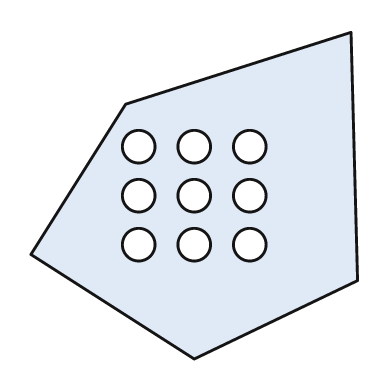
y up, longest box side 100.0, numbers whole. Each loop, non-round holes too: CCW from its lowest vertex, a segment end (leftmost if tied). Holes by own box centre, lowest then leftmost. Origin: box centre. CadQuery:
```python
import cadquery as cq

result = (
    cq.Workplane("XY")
    .moveTo(0.0, -50.0)
    .lineTo(50.0, -26.0)
    .lineTo(48.0, 50.0)
    .lineTo(-21.0, 28.0)
    .lineTo(-50.0, -18.0)
    .close()
    .moveTo(-17.0, -15.0)
    .circle(5.0)
    .moveTo(0.0, -15.0)
    .circle(5.0)
    .moveTo(17.0, -15.0)
    .circle(5.0)
    .moveTo(-17.0, 0.0)
    .circle(5.0)
    .moveTo(0.0, 0.0)
    .circle(5.0)
    .moveTo(17.0, 0.0)
    .circle(5.0)
    .moveTo(-17.0, 15.0)
    .circle(5.0)
    .moveTo(0.0, 15.0)
    .circle(5.0)
    .moveTo(17.0, 15.0)
    .circle(5.0)
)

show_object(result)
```